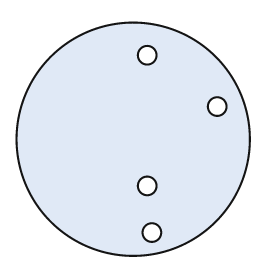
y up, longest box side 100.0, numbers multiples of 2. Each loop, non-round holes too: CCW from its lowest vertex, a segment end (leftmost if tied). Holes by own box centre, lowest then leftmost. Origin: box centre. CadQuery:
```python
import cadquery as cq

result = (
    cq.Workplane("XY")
    .moveTo(0.0, 0.0)
    .circle(50.0)
    .moveTo(8.0, -40.0)
    .circle(4.0)
    .moveTo(6.0, -20.0)
    .circle(4.0)
    .moveTo(36.0, 14.0)
    .circle(4.0)
    .moveTo(6.0, 36.0)
    .circle(4.0)
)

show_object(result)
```